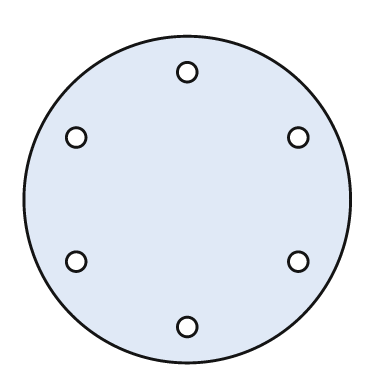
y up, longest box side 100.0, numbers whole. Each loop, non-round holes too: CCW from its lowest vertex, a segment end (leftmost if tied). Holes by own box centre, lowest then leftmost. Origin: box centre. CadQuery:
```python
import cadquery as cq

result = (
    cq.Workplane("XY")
    .moveTo(0.0, 0.0)
    .circle(50.0)
    .moveTo(0.0, -39.0)
    .circle(3.0)
    .moveTo(-34.0, -19.0)
    .circle(3.0)
    .moveTo(34.0, -19.0)
    .circle(3.0)
    .moveTo(-34.0, 19.0)
    .circle(3.0)
    .moveTo(34.0, 19.0)
    .circle(3.0)
    .moveTo(0.0, 39.0)
    .circle(3.0)
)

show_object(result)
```